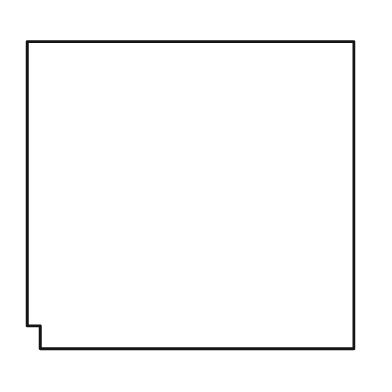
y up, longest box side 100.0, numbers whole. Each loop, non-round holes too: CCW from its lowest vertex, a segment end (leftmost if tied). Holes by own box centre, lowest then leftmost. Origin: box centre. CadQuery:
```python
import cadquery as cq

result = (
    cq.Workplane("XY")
    .moveTo(-46.0, -47.0)
    .lineTo(50.0, -47.0)
    .lineTo(50.0, 47.0)
    .lineTo(-50.0, 47.0)
    .lineTo(-50.0, -40.0)
    .lineTo(-46.0, -40.0)
    .close()
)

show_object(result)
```